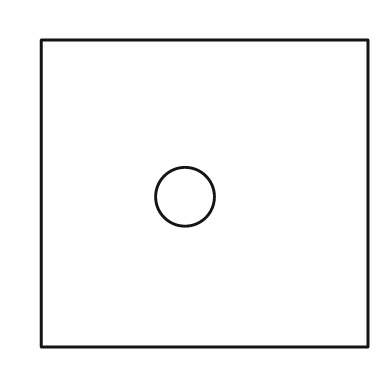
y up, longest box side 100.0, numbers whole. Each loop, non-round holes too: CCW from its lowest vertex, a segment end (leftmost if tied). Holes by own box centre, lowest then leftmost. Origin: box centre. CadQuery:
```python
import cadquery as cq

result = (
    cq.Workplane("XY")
    .moveTo(-50.0, -47.0)
    .lineTo(50.0, -47.0)
    .lineTo(50.0, 47.0)
    .lineTo(-50.0, 47.0)
    .close()
    .moveTo(-6.0, -1.0)
    .circle(9.0)
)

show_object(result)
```